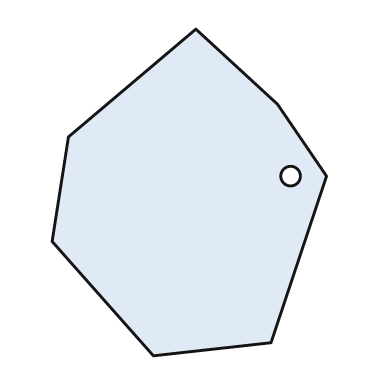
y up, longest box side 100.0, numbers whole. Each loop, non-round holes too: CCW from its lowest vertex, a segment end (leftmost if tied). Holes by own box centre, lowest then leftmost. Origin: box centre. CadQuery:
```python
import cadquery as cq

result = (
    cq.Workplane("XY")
    .moveTo(-11.0, -50.0)
    .lineTo(25.0, -46.0)
    .lineTo(42.0, 5.0)
    .lineTo(27.0, 27.0)
    .lineTo(2.0, 50.0)
    .lineTo(-37.0, 17.0)
    .lineTo(-42.0, -15.0)
    .close()
    .moveTo(31.0, 5.0)
    .circle(3.0)
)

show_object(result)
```